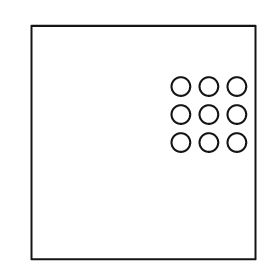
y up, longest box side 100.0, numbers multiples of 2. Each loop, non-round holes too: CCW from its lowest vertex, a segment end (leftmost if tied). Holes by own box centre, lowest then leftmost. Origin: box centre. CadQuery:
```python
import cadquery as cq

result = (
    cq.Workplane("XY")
    .moveTo(-48.0, -50.0)
    .lineTo(48.0, -50.0)
    .lineTo(48.0, 50.0)
    .lineTo(-48.0, 50.0)
    .close()
    .moveTo(16.0, 0.0)
    .circle(4.0)
    .moveTo(28.0, 0.0)
    .circle(4.0)
    .moveTo(40.0, 0.0)
    .circle(4.0)
    .moveTo(16.0, 12.0)
    .circle(4.0)
    .moveTo(28.0, 12.0)
    .circle(4.0)
    .moveTo(40.0, 12.0)
    .circle(4.0)
    .moveTo(16.0, 24.0)
    .circle(4.0)
    .moveTo(28.0, 24.0)
    .circle(4.0)
    .moveTo(40.0, 24.0)
    .circle(4.0)
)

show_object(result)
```